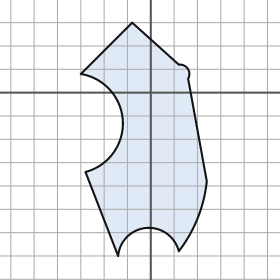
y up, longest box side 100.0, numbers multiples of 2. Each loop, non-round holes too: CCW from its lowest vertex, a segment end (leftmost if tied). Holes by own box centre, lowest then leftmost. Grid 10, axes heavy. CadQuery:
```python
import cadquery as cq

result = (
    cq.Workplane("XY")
    .moveTo(-14.0, -70.0)
    .threePointArc((-2.0, -58.0), (12.0, -68.0))
    .threePointArc((20.0, -54.0), (24.0, -38.0))
    .lineTo(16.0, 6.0)
    .threePointArc((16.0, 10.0), (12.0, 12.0))
    .lineTo(-8.0, 30.0)
    .lineTo(-30.0, 8.0)
    .threePointArc((-12.0, -12.0), (-28.0, -34.0))
    .close()
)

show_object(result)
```